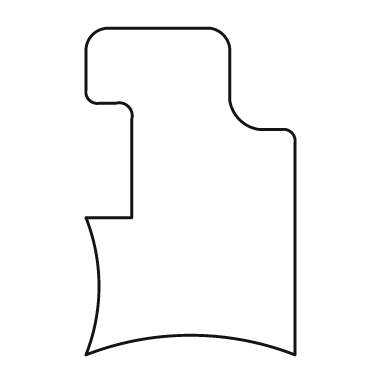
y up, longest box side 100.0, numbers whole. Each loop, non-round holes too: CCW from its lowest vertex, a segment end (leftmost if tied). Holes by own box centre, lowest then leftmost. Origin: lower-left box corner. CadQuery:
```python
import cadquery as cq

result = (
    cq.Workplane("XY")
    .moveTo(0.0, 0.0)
    .threePointArc((32.0, 6.0), (64.0, 0.0))
    .lineTo(64.0, 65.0)
    .threePointArc((63.0, 68.0), (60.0, 69.0))
    .lineTo(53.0, 69.0)
    .threePointArc((47.0, 72.0), (44.0, 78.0))
    .lineTo(44.0, 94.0)
    .threePointArc((42.0, 98.0), (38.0, 100.0))
    .lineTo(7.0, 100.0)
    .threePointArc((2.0, 98.0), (0.0, 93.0))
    .lineTo(0.0, 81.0)
    .threePointArc((1.0, 78.0), (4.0, 77.0))
    .lineTo(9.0, 77.0)
    .threePointArc((13.0, 76.0), (14.0, 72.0))
    .lineTo(14.0, 42.0)
    .lineTo(0.0, 42.0)
    .threePointArc((4.0, 21.0), (0.0, 0.0))
    .close()
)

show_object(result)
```